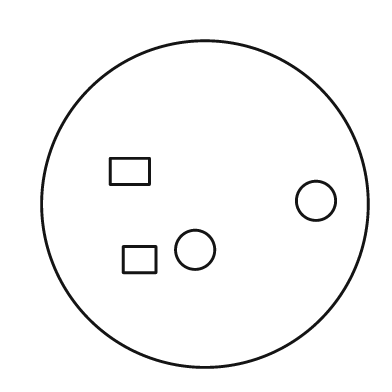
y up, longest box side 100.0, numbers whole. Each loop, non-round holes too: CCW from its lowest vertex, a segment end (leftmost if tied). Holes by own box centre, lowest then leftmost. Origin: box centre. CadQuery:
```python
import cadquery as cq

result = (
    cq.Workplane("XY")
    .moveTo(0.0, 0.0)
    .circle(50.0)
    .moveTo(-25.0, -21.0)
    .lineTo(-15.0, -21.0)
    .lineTo(-15.0, -13.0)
    .lineTo(-25.0, -13.0)
    .close()
    .moveTo(-3.0, -14.0)
    .circle(6.0)
    .moveTo(34.0, 1.0)
    .circle(6.0)
    .moveTo(-29.0, 6.0)
    .lineTo(-17.0, 6.0)
    .lineTo(-17.0, 14.0)
    .lineTo(-29.0, 14.0)
    .close()
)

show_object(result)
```